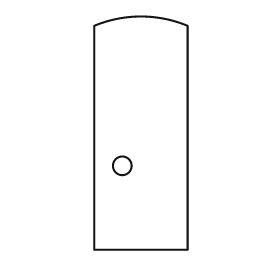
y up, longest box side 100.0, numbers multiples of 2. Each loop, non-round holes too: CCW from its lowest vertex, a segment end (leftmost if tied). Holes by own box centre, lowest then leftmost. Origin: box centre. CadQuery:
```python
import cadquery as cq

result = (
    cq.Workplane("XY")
    .moveTo(-20.0, -50.0)
    .lineTo(20.0, -50.0)
    .lineTo(20.0, 46.0)
    .threePointArc((0.0, 50.0), (-20.0, 46.0))
    .close()
    .moveTo(-8.0, -14.0)
    .circle(4.0)
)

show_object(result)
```